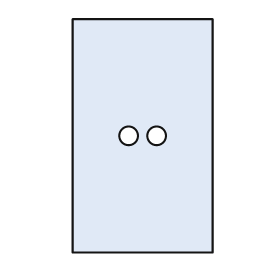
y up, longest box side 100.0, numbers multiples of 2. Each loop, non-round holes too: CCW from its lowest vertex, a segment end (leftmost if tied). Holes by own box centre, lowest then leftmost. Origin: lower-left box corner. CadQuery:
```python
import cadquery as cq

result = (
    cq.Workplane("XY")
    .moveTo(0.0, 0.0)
    .lineTo(60.0, 0.0)
    .lineTo(60.0, 100.0)
    .lineTo(0.0, 100.0)
    .close()
    .moveTo(24.0, 50.0)
    .circle(4.0)
    .moveTo(36.0, 50.0)
    .circle(4.0)
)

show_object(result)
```